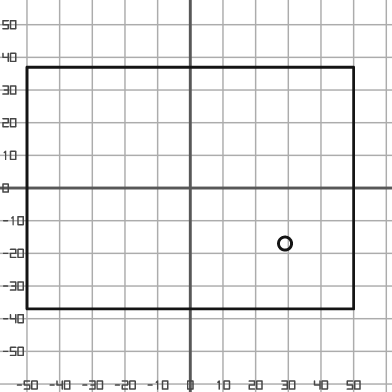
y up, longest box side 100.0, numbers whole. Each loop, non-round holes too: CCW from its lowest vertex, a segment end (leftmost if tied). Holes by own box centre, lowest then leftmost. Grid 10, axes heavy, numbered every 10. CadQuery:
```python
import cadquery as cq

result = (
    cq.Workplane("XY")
    .moveTo(-50.0, -37.0)
    .lineTo(50.0, -37.0)
    .lineTo(50.0, 37.0)
    .lineTo(-50.0, 37.0)
    .close()
    .moveTo(29.0, -17.0)
    .circle(2.0)
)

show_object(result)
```